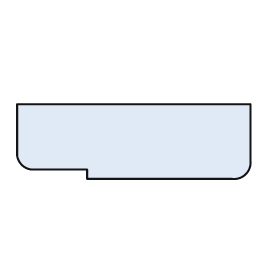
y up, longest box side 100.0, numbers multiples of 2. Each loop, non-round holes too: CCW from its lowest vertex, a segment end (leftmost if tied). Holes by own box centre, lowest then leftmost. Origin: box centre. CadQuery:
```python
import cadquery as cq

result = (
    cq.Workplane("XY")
    .moveTo(-20.0, -16.0)
    .lineTo(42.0, -16.0)
    .threePointArc((48.0, -14.0), (50.0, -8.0))
    .lineTo(50.0, 16.0)
    .lineTo(-50.0, 16.0)
    .lineTo(-50.0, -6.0)
    .threePointArc((-48.0, -10.0), (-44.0, -12.0))
    .lineTo(-20.0, -12.0)
    .close()
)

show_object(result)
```